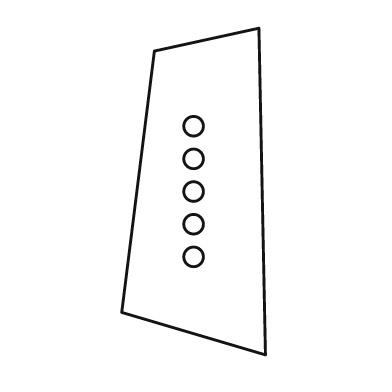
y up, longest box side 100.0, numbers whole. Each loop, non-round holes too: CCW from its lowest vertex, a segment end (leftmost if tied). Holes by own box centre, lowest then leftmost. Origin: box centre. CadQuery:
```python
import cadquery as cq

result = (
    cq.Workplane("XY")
    .moveTo(22.0, -50.0)
    .lineTo(20.0, 50.0)
    .lineTo(-12.0, 43.0)
    .lineTo(-22.0, -37.0)
    .close()
    .moveTo(0.0, -20.0)
    .circle(3.0)
    .moveTo(0.0, -10.0)
    .circle(3.0)
    .moveTo(0.0, 0.0)
    .circle(3.0)
    .moveTo(0.0, 10.0)
    .circle(3.0)
    .moveTo(0.0, 20.0)
    .circle(3.0)
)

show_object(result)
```